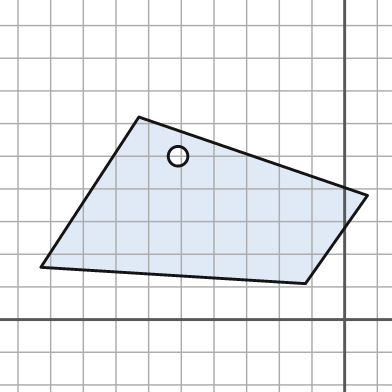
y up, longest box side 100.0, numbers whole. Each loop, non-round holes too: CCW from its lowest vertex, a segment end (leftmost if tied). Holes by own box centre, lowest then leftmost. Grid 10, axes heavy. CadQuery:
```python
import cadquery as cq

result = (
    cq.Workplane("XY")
    .moveTo(-12.0, 11.0)
    .lineTo(7.0, 38.0)
    .lineTo(-63.0, 62.0)
    .lineTo(-93.0, 16.0)
    .close()
    .moveTo(-51.0, 50.0)
    .circle(3.0)
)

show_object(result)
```